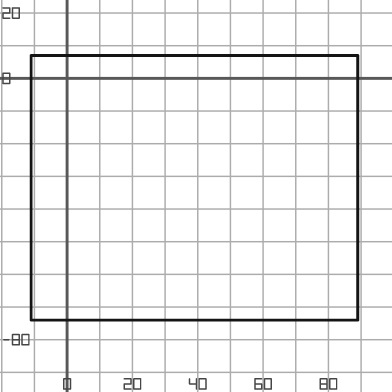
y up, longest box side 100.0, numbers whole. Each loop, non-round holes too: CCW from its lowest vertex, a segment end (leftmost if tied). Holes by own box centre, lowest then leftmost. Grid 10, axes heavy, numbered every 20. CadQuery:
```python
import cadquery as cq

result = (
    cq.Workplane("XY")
    .moveTo(-11.0, -74.0)
    .lineTo(89.0, -74.0)
    .lineTo(89.0, 7.0)
    .lineTo(-11.0, 7.0)
    .close()
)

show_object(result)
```